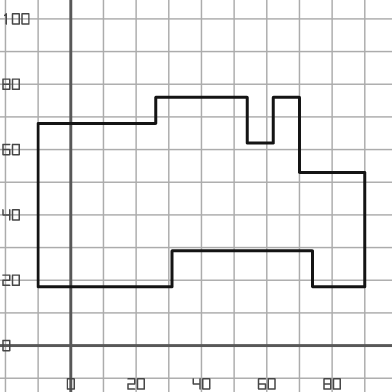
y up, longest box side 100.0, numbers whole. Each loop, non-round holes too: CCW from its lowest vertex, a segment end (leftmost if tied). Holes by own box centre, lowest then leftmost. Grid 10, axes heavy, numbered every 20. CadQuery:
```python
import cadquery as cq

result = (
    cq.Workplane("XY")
    .moveTo(-10.0, 18.0)
    .lineTo(31.0, 18.0)
    .lineTo(31.0, 29.0)
    .lineTo(74.0, 29.0)
    .lineTo(74.0, 18.0)
    .lineTo(90.0, 18.0)
    .lineTo(90.0, 53.0)
    .lineTo(70.0, 53.0)
    .lineTo(70.0, 76.0)
    .lineTo(62.0, 76.0)
    .lineTo(62.0, 62.0)
    .lineTo(54.0, 62.0)
    .lineTo(54.0, 76.0)
    .lineTo(26.0, 76.0)
    .lineTo(26.0, 68.0)
    .lineTo(-10.0, 68.0)
    .close()
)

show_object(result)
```